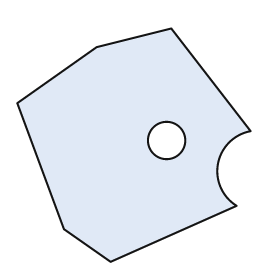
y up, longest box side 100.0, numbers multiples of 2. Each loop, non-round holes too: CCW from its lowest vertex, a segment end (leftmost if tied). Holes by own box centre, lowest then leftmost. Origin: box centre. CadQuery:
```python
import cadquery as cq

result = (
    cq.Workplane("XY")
    .moveTo(-10.0, -50.0)
    .lineTo(44.0, -26.0)
    .threePointArc((36.0, -8.0), (50.0, 6.0))
    .lineTo(16.0, 50.0)
    .lineTo(-16.0, 42.0)
    .lineTo(-50.0, 18.0)
    .lineTo(-30.0, -36.0)
    .close()
    .moveTo(14.0, 2.0)
    .circle(8.0)
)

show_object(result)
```